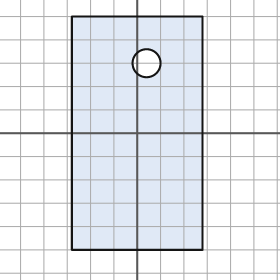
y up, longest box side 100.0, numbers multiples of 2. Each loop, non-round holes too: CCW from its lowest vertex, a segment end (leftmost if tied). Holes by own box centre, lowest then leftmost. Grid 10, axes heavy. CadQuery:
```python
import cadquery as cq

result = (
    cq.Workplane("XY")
    .moveTo(-28.0, -50.0)
    .lineTo(28.0, -50.0)
    .lineTo(28.0, 50.0)
    .lineTo(-28.0, 50.0)
    .close()
    .moveTo(4.0, 30.0)
    .circle(6.0)
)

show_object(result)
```